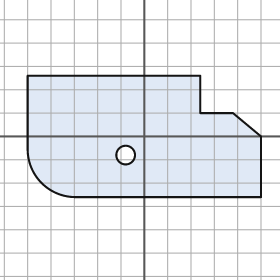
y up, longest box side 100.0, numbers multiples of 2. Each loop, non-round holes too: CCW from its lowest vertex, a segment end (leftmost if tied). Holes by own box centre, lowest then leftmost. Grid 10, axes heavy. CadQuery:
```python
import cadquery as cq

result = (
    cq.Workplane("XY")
    .moveTo(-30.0, -26.0)
    .lineTo(50.0, -26.0)
    .lineTo(50.0, 0.0)
    .lineTo(38.0, 10.0)
    .lineTo(24.0, 10.0)
    .lineTo(24.0, 26.0)
    .lineTo(-50.0, 26.0)
    .lineTo(-50.0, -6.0)
    .threePointArc((-44.0, -20.0), (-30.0, -26.0))
    .close()
    .moveTo(-8.0, -8.0)
    .circle(4.0)
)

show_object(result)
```